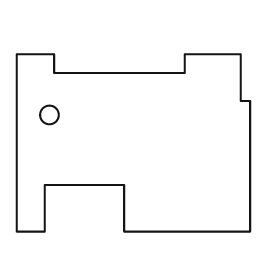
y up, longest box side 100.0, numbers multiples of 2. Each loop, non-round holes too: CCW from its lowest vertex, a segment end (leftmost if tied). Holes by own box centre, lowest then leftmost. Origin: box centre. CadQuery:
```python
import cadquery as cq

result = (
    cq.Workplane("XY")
    .moveTo(-50.0, -38.0)
    .lineTo(-38.0, -38.0)
    .lineTo(-38.0, -18.0)
    .lineTo(-4.0, -18.0)
    .lineTo(-4.0, -38.0)
    .lineTo(50.0, -38.0)
    .lineTo(50.0, 18.0)
    .lineTo(46.0, 18.0)
    .lineTo(46.0, 38.0)
    .lineTo(22.0, 38.0)
    .lineTo(22.0, 30.0)
    .lineTo(-34.0, 30.0)
    .lineTo(-34.0, 38.0)
    .lineTo(-50.0, 38.0)
    .close()
    .moveTo(-36.0, 12.0)
    .circle(4.0)
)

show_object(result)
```